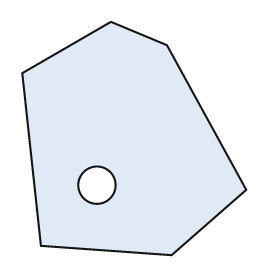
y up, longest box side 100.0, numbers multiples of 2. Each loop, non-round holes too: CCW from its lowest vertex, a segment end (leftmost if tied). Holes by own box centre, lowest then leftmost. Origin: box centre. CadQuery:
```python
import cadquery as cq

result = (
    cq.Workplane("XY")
    .moveTo(16.0, -50.0)
    .lineTo(48.0, -22.0)
    .lineTo(14.0, 40.0)
    .lineTo(-10.0, 50.0)
    .lineTo(-48.0, 28.0)
    .lineTo(-40.0, -46.0)
    .close()
    .moveTo(-16.0, -20.0)
    .circle(8.0)
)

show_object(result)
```